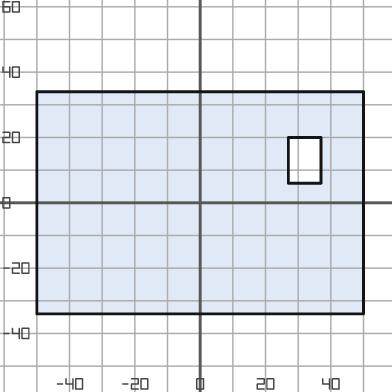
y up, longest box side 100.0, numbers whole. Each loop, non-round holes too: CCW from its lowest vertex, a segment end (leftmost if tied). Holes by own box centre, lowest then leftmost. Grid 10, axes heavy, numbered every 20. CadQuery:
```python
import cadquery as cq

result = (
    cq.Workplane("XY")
    .moveTo(-50.0, -34.0)
    .lineTo(50.0, -34.0)
    .lineTo(50.0, 34.0)
    .lineTo(-50.0, 34.0)
    .close()
    .moveTo(27.0, 6.0)
    .lineTo(37.0, 6.0)
    .lineTo(37.0, 20.0)
    .lineTo(27.0, 20.0)
    .close()
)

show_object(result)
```